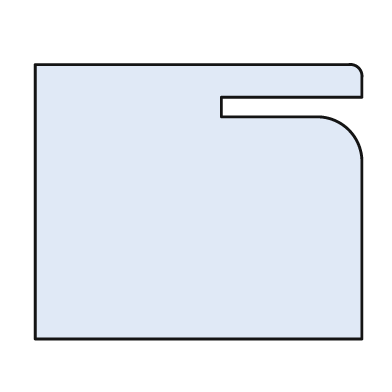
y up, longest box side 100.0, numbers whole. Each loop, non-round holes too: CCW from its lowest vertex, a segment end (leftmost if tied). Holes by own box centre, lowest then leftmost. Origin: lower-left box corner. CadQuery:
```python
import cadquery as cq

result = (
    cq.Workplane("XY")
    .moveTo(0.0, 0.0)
    .lineTo(100.0, 0.0)
    .lineTo(100.0, 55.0)
    .threePointArc((96.0, 64.0), (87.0, 68.0))
    .lineTo(57.0, 68.0)
    .lineTo(57.0, 74.0)
    .lineTo(100.0, 74.0)
    .lineTo(100.0, 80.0)
    .threePointArc((99.0, 83.0), (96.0, 84.0))
    .lineTo(0.0, 84.0)
    .close()
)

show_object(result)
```